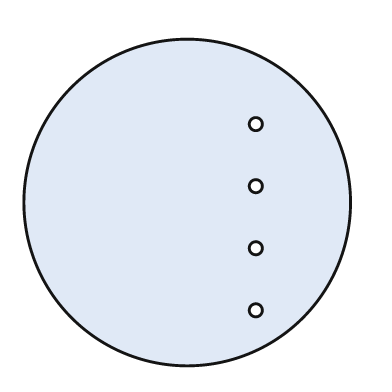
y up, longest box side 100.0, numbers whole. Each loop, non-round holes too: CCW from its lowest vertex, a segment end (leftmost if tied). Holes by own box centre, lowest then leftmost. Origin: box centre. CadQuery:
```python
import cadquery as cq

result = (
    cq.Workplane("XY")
    .moveTo(0.0, 0.0)
    .circle(50.0)
    .moveTo(21.0, -33.0)
    .circle(2.0)
    .moveTo(21.0, -14.0)
    .circle(2.0)
    .moveTo(21.0, 5.0)
    .circle(2.0)
    .moveTo(21.0, 24.0)
    .circle(2.0)
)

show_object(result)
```